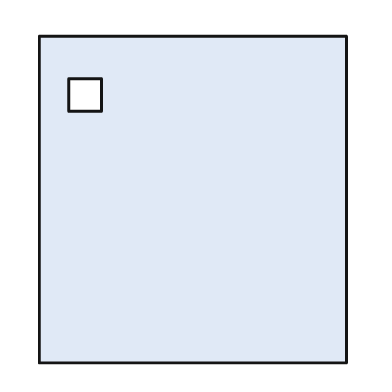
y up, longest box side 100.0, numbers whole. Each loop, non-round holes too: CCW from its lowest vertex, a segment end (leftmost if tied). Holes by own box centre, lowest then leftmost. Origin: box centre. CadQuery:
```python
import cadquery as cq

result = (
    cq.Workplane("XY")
    .moveTo(-47.0, -50.0)
    .lineTo(47.0, -50.0)
    .lineTo(47.0, 50.0)
    .lineTo(-47.0, 50.0)
    .close()
    .moveTo(-38.0, 27.0)
    .lineTo(-28.0, 27.0)
    .lineTo(-28.0, 37.0)
    .lineTo(-38.0, 37.0)
    .close()
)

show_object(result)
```